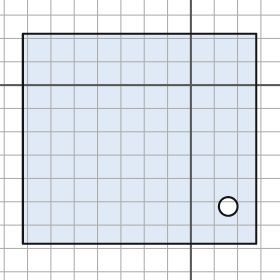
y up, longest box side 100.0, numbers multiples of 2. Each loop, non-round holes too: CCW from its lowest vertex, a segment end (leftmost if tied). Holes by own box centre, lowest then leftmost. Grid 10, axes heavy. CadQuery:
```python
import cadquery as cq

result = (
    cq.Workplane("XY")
    .moveTo(-72.0, -68.0)
    .lineTo(28.0, -68.0)
    .lineTo(28.0, 22.0)
    .lineTo(-72.0, 22.0)
    .close()
    .moveTo(16.0, -52.0)
    .circle(4.0)
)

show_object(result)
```